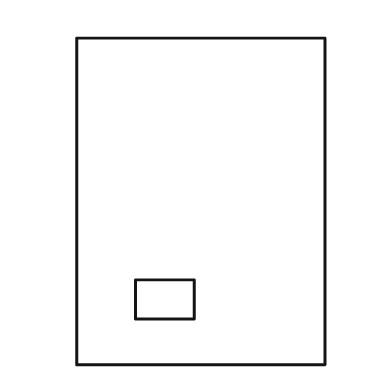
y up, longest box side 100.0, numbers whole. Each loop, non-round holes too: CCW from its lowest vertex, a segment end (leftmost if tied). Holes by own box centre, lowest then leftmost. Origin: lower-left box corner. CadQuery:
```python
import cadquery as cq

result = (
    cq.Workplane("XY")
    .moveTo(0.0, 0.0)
    .lineTo(76.0, 0.0)
    .lineTo(76.0, 100.0)
    .lineTo(0.0, 100.0)
    .close()
    .moveTo(18.0, 14.0)
    .lineTo(36.0, 14.0)
    .lineTo(36.0, 26.0)
    .lineTo(18.0, 26.0)
    .close()
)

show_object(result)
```